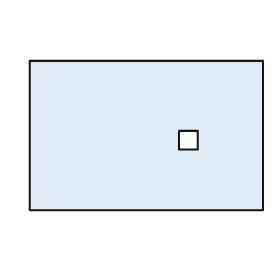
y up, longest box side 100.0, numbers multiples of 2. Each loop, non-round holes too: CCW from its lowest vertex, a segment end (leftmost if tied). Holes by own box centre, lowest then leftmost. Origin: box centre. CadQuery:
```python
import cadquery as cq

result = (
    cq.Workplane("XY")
    .moveTo(-50.0, -32.0)
    .lineTo(50.0, -32.0)
    .lineTo(50.0, 32.0)
    .lineTo(-50.0, 32.0)
    .close()
    .moveTo(14.0, -6.0)
    .lineTo(22.0, -6.0)
    .lineTo(22.0, 2.0)
    .lineTo(14.0, 2.0)
    .close()
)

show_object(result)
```